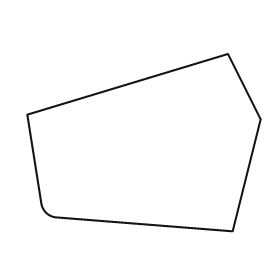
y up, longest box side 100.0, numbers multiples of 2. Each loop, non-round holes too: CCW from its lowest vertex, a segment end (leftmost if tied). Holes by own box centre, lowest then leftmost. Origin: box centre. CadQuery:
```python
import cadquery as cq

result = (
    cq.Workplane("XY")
    .moveTo(38.0, -38.0)
    .lineTo(50.0, 10.0)
    .lineTo(36.0, 38.0)
    .lineTo(-50.0, 12.0)
    .lineTo(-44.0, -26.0)
    .threePointArc((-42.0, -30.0), (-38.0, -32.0))
    .close()
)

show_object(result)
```